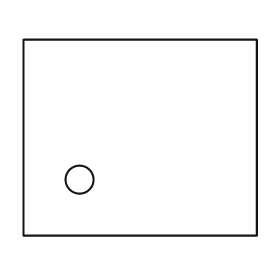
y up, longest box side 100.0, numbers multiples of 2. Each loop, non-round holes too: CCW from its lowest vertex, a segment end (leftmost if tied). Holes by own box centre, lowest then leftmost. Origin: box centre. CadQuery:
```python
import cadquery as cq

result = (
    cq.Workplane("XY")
    .moveTo(-50.0, -42.0)
    .lineTo(50.0, -42.0)
    .lineTo(50.0, 42.0)
    .lineTo(-50.0, 42.0)
    .close()
    .moveTo(-26.0, -18.0)
    .circle(6.0)
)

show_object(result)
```